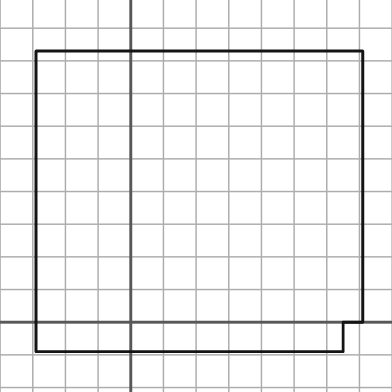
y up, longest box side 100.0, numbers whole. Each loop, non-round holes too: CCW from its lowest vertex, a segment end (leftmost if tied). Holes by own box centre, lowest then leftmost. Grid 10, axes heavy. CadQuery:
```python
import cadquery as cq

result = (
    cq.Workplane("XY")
    .moveTo(-29.0, -9.0)
    .lineTo(65.0, -9.0)
    .lineTo(65.0, 0.0)
    .lineTo(71.0, 0.0)
    .lineTo(71.0, 83.0)
    .lineTo(-29.0, 83.0)
    .close()
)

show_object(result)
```